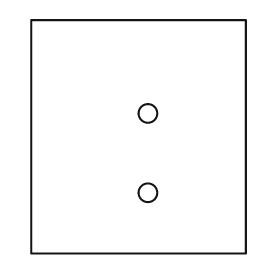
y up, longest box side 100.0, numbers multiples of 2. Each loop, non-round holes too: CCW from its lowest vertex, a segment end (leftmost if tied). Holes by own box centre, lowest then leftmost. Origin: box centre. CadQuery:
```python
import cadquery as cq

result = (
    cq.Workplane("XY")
    .moveTo(-46.0, -50.0)
    .lineTo(46.0, -50.0)
    .lineTo(46.0, 50.0)
    .lineTo(-46.0, 50.0)
    .close()
    .moveTo(4.0, -24.0)
    .circle(4.0)
    .moveTo(4.0, 10.0)
    .circle(4.0)
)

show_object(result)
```